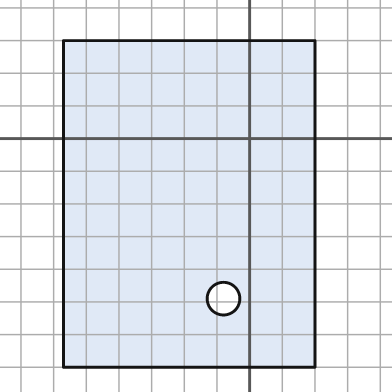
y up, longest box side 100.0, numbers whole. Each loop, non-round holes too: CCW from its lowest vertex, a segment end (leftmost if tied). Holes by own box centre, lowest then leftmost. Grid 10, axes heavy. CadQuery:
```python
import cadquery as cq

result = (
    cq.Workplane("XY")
    .moveTo(-57.0, -70.0)
    .lineTo(20.0, -70.0)
    .lineTo(20.0, 30.0)
    .lineTo(-57.0, 30.0)
    .close()
    .moveTo(-8.0, -49.0)
    .circle(5.0)
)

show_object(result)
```